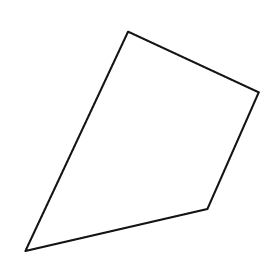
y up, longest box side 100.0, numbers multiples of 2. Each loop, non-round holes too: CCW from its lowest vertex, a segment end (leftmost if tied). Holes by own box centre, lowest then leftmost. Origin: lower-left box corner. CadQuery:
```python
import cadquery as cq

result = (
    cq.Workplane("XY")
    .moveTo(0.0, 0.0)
    .lineTo(78.0, 18.0)
    .lineTo(100.0, 68.0)
    .lineTo(44.0, 94.0)
    .close()
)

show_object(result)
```